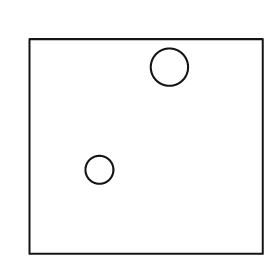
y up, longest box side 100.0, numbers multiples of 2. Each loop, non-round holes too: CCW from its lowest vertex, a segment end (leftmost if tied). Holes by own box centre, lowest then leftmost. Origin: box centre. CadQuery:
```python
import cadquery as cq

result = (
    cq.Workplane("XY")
    .moveTo(-50.0, -46.0)
    .lineTo(50.0, -46.0)
    .lineTo(50.0, 46.0)
    .lineTo(-50.0, 46.0)
    .close()
    .moveTo(-20.0, -10.0)
    .circle(6.0)
    .moveTo(10.0, 34.0)
    .circle(8.0)
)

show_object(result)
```